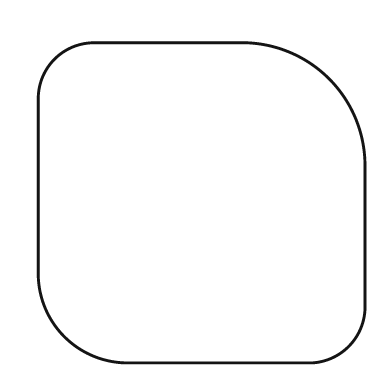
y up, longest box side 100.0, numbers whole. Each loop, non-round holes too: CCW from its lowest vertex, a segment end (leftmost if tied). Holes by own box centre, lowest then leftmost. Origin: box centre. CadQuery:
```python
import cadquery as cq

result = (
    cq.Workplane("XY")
    .moveTo(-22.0, -49.0)
    .lineTo(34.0, -49.0)
    .threePointArc((45.0, -44.0), (50.0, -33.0))
    .lineTo(50.0, 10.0)
    .threePointArc((39.0, 38.0), (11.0, 49.0))
    .lineTo(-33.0, 49.0)
    .threePointArc((-45.0, 44.0), (-50.0, 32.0))
    .lineTo(-50.0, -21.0)
    .threePointArc((-42.0, -41.0), (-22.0, -49.0))
    .close()
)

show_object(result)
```